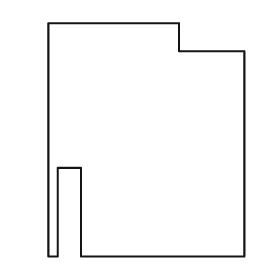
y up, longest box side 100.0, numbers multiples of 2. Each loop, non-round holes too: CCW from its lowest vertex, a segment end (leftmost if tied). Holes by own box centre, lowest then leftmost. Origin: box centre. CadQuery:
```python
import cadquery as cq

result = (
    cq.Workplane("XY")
    .moveTo(-42.0, -50.0)
    .lineTo(-38.0, -50.0)
    .lineTo(-38.0, -12.0)
    .lineTo(-28.0, -12.0)
    .lineTo(-28.0, -50.0)
    .lineTo(42.0, -50.0)
    .lineTo(42.0, 38.0)
    .lineTo(14.0, 38.0)
    .lineTo(14.0, 50.0)
    .lineTo(-42.0, 50.0)
    .close()
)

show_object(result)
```